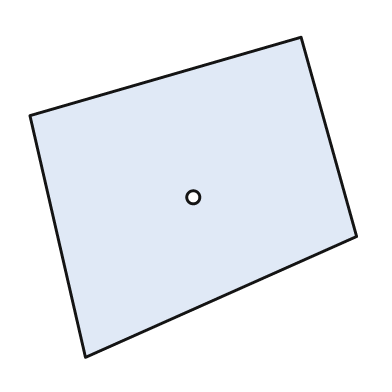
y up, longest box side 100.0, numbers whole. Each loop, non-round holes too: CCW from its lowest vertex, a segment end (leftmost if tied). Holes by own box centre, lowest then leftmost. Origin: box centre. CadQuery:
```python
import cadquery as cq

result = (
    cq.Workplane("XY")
    .moveTo(-33.0, -49.0)
    .lineTo(50.0, -12.0)
    .lineTo(33.0, 49.0)
    .lineTo(-50.0, 25.0)
    .close()
    .moveTo(0.0, 0.0)
    .circle(2.0)
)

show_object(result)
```